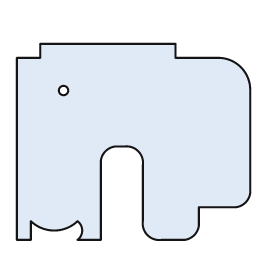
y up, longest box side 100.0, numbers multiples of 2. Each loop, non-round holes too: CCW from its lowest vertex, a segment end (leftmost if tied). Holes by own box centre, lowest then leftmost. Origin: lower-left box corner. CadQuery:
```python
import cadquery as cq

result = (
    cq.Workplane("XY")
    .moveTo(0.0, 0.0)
    .lineTo(6.0, 0.0)
    .lineTo(6.0, 8.0)
    .threePointArc((16.0, 4.0), (26.0, 8.0))
    .threePointArc((28.0, 4.0), (26.0, 0.0))
    .lineTo(36.0, 0.0)
    .lineTo(36.0, 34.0)
    .threePointArc((38.0, 38.0), (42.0, 40.0))
    .lineTo(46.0, 40.0)
    .threePointArc((52.0, 38.0), (54.0, 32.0))
    .lineTo(54.0, 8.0)
    .threePointArc((56.0, 2.0), (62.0, 0.0))
    .lineTo(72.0, 0.0)
    .threePointArc((76.0, 2.0), (78.0, 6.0))
    .lineTo(78.0, 14.0)
    .lineTo(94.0, 14.0)
    .threePointArc((98.0, 16.0), (100.0, 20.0))
    .lineTo(100.0, 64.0)
    .threePointArc((96.0, 74.0), (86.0, 78.0))
    .lineTo(68.0, 78.0)
    .lineTo(68.0, 84.0)
    .lineTo(10.0, 84.0)
    .lineTo(10.0, 78.0)
    .lineTo(0.0, 78.0)
    .close()
    .moveTo(20.0, 64.0)
    .circle(2.0)
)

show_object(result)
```